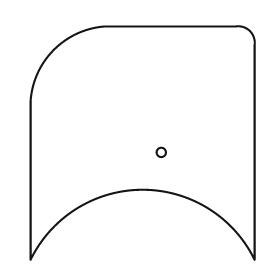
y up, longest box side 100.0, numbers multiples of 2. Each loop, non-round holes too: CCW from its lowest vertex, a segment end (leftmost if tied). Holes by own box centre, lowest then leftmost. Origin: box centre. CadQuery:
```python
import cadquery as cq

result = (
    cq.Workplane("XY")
    .moveTo(-48.0, -50.0)
    .threePointArc((0.0, -20.0), (48.0, -50.0))
    .lineTo(48.0, 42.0)
    .threePointArc((46.0, 48.0), (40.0, 50.0))
    .lineTo(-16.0, 50.0)
    .threePointArc((-38.0, 40.0), (-48.0, 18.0))
    .close()
    .moveTo(8.0, -4.0)
    .circle(2.0)
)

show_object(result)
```